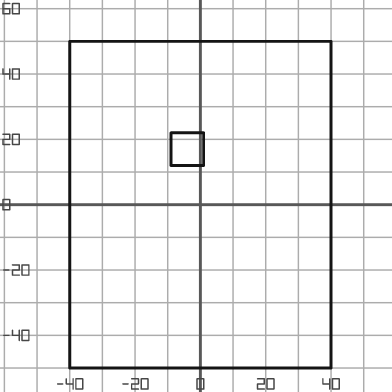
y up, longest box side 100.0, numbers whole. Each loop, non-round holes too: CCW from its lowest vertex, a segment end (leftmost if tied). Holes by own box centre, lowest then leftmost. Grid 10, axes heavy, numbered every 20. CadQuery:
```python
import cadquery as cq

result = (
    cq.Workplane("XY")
    .moveTo(-40.0, -50.0)
    .lineTo(40.0, -50.0)
    .lineTo(40.0, 50.0)
    .lineTo(-40.0, 50.0)
    .close()
    .moveTo(-9.0, 12.0)
    .lineTo(1.0, 12.0)
    .lineTo(1.0, 22.0)
    .lineTo(-9.0, 22.0)
    .close()
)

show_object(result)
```